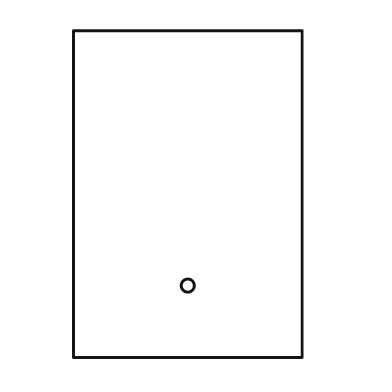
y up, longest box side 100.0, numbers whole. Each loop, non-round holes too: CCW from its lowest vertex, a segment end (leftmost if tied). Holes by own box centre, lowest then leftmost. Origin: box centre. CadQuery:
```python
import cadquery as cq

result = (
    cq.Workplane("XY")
    .moveTo(-35.0, -50.0)
    .lineTo(35.0, -50.0)
    .lineTo(35.0, 50.0)
    .lineTo(-35.0, 50.0)
    .close()
    .moveTo(0.0, -28.0)
    .circle(2.0)
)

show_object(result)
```